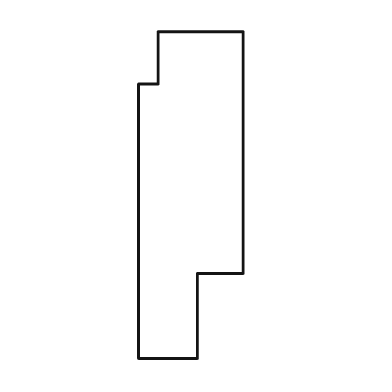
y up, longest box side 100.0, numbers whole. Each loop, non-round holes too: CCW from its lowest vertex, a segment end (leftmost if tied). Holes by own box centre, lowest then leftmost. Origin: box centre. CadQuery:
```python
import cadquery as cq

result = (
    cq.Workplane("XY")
    .moveTo(-16.0, -50.0)
    .lineTo(2.0, -50.0)
    .lineTo(2.0, -24.0)
    .lineTo(16.0, -24.0)
    .lineTo(16.0, 50.0)
    .lineTo(-10.0, 50.0)
    .lineTo(-10.0, 34.0)
    .lineTo(-16.0, 34.0)
    .close()
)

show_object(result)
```